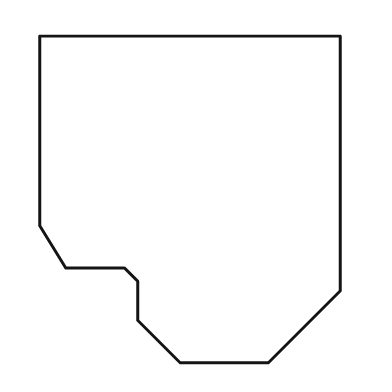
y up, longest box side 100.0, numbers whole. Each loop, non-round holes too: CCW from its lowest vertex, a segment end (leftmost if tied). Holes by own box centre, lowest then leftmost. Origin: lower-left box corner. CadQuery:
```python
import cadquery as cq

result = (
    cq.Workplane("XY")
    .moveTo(43.0, 0.0)
    .lineTo(70.0, 0.0)
    .lineTo(92.0, 22.0)
    .lineTo(92.0, 100.0)
    .lineTo(0.0, 100.0)
    .lineTo(0.0, 42.0)
    .lineTo(8.0, 29.0)
    .lineTo(26.0, 29.0)
    .lineTo(30.0, 25.0)
    .lineTo(30.0, 13.0)
    .close()
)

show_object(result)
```